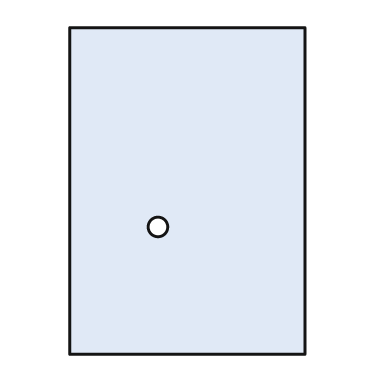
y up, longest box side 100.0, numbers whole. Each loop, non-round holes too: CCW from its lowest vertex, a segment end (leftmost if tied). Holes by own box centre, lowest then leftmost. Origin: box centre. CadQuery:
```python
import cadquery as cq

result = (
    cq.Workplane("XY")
    .moveTo(-36.0, -50.0)
    .lineTo(36.0, -50.0)
    .lineTo(36.0, 50.0)
    .lineTo(-36.0, 50.0)
    .close()
    .moveTo(-9.0, -11.0)
    .circle(3.0)
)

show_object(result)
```